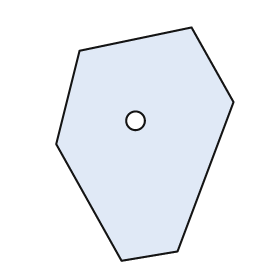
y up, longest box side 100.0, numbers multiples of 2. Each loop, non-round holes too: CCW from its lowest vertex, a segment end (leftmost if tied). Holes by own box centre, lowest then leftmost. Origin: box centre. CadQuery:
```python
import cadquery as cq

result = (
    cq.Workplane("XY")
    .moveTo(-10.0, -50.0)
    .lineTo(14.0, -46.0)
    .lineTo(38.0, 18.0)
    .lineTo(20.0, 50.0)
    .lineTo(-28.0, 40.0)
    .lineTo(-38.0, 0.0)
    .close()
    .moveTo(-4.0, 10.0)
    .circle(4.0)
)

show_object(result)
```